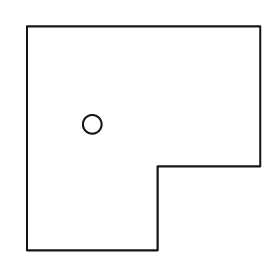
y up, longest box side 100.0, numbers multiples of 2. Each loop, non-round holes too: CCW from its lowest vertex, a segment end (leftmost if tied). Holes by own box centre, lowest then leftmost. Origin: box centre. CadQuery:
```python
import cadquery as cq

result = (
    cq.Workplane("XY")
    .moveTo(-50.0, -48.0)
    .lineTo(6.0, -48.0)
    .lineTo(6.0, -12.0)
    .lineTo(50.0, -12.0)
    .lineTo(50.0, 48.0)
    .lineTo(-50.0, 48.0)
    .close()
    .moveTo(-22.0, 6.0)
    .circle(4.0)
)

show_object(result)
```